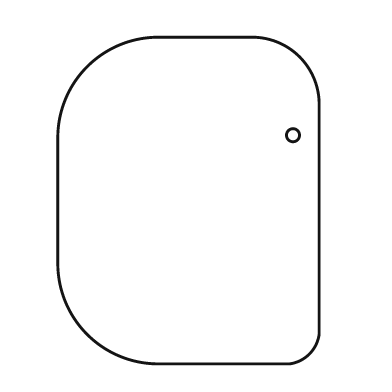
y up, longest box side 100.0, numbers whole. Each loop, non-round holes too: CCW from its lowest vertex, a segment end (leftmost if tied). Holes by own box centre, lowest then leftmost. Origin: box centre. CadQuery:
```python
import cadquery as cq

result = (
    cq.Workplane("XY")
    .moveTo(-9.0, -50.0)
    .lineTo(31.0, -50.0)
    .threePointArc((37.0, -47.0), (40.0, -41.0))
    .lineTo(40.0, 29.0)
    .threePointArc((34.0, 44.0), (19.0, 50.0))
    .lineTo(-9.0, 50.0)
    .threePointArc((-31.0, 41.0), (-40.0, 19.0))
    .lineTo(-40.0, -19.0)
    .threePointArc((-31.0, -41.0), (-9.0, -50.0))
    .close()
    .moveTo(32.0, 20.0)
    .circle(2.0)
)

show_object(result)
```